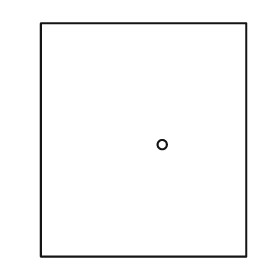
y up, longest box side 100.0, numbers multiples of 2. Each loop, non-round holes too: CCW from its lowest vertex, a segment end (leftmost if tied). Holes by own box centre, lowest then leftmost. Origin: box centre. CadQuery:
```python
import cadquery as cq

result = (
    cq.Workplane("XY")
    .moveTo(-44.0, -50.0)
    .lineTo(44.0, -50.0)
    .lineTo(44.0, 50.0)
    .lineTo(-44.0, 50.0)
    .close()
    .moveTo(8.0, -2.0)
    .circle(2.0)
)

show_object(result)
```